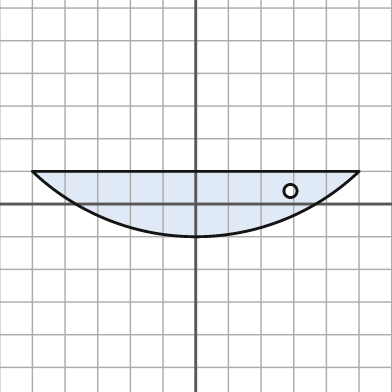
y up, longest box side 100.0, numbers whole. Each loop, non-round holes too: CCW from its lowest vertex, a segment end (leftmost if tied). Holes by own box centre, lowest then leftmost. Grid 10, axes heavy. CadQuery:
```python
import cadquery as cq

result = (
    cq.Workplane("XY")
    .moveTo(-50.0, 10.0)
    .threePointArc((0.0, -10.0), (50.0, 10.0))
    .close()
    .moveTo(29.0, 4.0)
    .circle(2.0)
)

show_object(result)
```